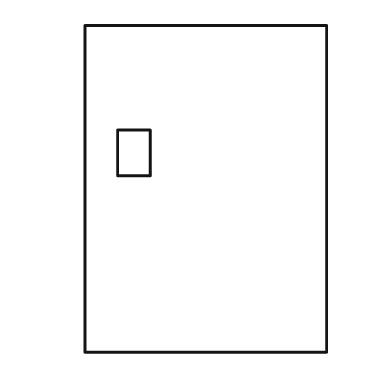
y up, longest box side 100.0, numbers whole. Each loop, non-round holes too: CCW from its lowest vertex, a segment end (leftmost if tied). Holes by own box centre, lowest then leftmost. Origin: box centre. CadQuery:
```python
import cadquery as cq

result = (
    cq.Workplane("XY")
    .moveTo(-37.0, -50.0)
    .lineTo(37.0, -50.0)
    .lineTo(37.0, 50.0)
    .lineTo(-37.0, 50.0)
    .close()
    .moveTo(-27.0, 4.0)
    .lineTo(-17.0, 4.0)
    .lineTo(-17.0, 18.0)
    .lineTo(-27.0, 18.0)
    .close()
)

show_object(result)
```